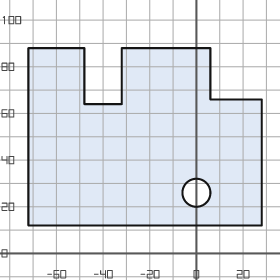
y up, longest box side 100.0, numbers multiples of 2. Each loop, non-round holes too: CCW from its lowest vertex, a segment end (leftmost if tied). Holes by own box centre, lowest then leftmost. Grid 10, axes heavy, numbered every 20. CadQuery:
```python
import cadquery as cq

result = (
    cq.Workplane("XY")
    .moveTo(-72.0, 12.0)
    .lineTo(28.0, 12.0)
    .lineTo(28.0, 66.0)
    .lineTo(6.0, 66.0)
    .lineTo(6.0, 88.0)
    .lineTo(-32.0, 88.0)
    .lineTo(-32.0, 64.0)
    .lineTo(-48.0, 64.0)
    .lineTo(-48.0, 88.0)
    .lineTo(-72.0, 88.0)
    .close()
    .moveTo(0.0, 26.0)
    .circle(6.0)
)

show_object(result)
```